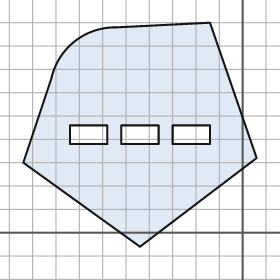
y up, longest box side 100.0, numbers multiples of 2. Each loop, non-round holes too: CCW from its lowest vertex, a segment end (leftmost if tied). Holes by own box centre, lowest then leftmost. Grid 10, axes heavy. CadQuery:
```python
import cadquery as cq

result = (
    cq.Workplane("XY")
    .moveTo(-44.0, -6.0)
    .lineTo(6.0, 32.0)
    .lineTo(-14.0, 90.0)
    .lineTo(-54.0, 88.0)
    .threePointArc((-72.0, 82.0), (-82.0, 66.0))
    .lineTo(-94.0, 30.0)
    .close()
    .moveTo(-74.0, 38.0)
    .lineTo(-58.0, 38.0)
    .lineTo(-58.0, 46.0)
    .lineTo(-74.0, 46.0)
    .close()
    .moveTo(-52.0, 38.0)
    .lineTo(-36.0, 38.0)
    .lineTo(-36.0, 46.0)
    .lineTo(-52.0, 46.0)
    .close()
    .moveTo(-30.0, 38.0)
    .lineTo(-14.0, 38.0)
    .lineTo(-14.0, 46.0)
    .lineTo(-30.0, 46.0)
    .close()
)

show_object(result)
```